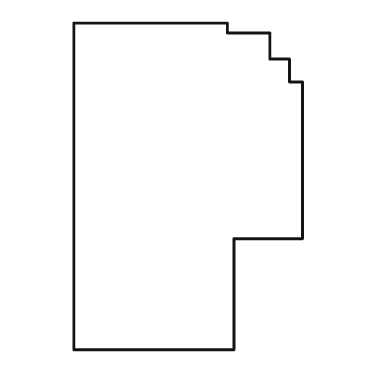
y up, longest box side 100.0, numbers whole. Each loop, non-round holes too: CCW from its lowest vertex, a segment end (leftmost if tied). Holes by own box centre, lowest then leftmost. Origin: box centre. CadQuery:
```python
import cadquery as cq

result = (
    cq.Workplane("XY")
    .moveTo(-35.0, -50.0)
    .lineTo(14.0, -50.0)
    .lineTo(14.0, -16.0)
    .lineTo(35.0, -16.0)
    .lineTo(35.0, 32.0)
    .lineTo(31.0, 32.0)
    .lineTo(31.0, 39.0)
    .lineTo(25.0, 39.0)
    .lineTo(25.0, 47.0)
    .lineTo(12.0, 47.0)
    .lineTo(12.0, 50.0)
    .lineTo(-35.0, 50.0)
    .close()
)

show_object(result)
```